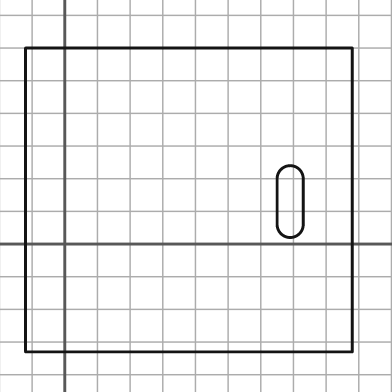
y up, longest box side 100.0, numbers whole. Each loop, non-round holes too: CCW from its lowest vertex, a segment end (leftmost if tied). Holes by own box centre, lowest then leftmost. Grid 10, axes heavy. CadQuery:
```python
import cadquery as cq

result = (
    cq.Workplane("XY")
    .moveTo(-12.0, -33.0)
    .lineTo(88.0, -33.0)
    .lineTo(88.0, 60.0)
    .lineTo(-12.0, 60.0)
    .close()
    .moveTo(65.0, 6.0)
    .threePointArc((69.0, 2.0), (73.0, 6.0))
    .lineTo(73.0, 20.0)
    .threePointArc((69.0, 24.0), (65.0, 20.0))
    .close()
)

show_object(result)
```